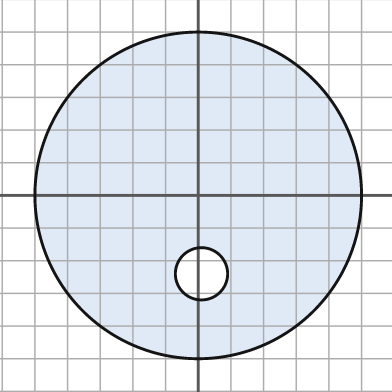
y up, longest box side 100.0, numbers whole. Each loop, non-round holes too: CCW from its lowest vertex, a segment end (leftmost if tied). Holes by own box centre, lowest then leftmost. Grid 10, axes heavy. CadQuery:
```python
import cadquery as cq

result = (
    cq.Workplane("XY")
    .moveTo(0.0, 0.0)
    .circle(50.0)
    .moveTo(1.0, -24.0)
    .circle(8.0)
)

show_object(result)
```